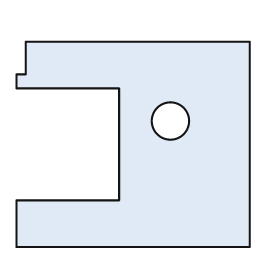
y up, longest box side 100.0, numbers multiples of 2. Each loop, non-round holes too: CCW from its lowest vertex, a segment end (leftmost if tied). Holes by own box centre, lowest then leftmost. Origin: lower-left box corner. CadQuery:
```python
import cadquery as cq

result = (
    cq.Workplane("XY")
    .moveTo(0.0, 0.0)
    .lineTo(100.0, 0.0)
    .lineTo(100.0, 88.0)
    .lineTo(4.0, 88.0)
    .lineTo(4.0, 74.0)
    .lineTo(0.0, 74.0)
    .lineTo(0.0, 68.0)
    .lineTo(44.0, 68.0)
    .lineTo(44.0, 20.0)
    .lineTo(0.0, 20.0)
    .close()
    .moveTo(66.0, 54.0)
    .circle(8.0)
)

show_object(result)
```